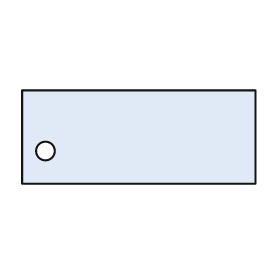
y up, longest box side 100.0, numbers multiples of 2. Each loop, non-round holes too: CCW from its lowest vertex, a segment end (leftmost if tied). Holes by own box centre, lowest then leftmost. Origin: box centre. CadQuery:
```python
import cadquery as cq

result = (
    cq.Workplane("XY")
    .moveTo(-50.0, -20.0)
    .lineTo(50.0, -20.0)
    .lineTo(50.0, 20.0)
    .lineTo(-50.0, 20.0)
    .close()
    .moveTo(-40.0, -6.0)
    .circle(4.0)
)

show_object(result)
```